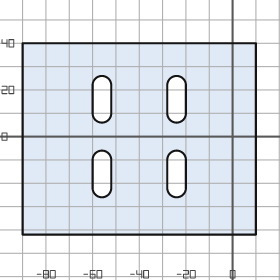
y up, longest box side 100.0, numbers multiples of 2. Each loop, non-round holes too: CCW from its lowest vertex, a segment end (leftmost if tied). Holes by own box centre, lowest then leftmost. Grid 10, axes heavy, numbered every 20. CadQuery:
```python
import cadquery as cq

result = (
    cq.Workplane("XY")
    .moveTo(-90.0, -42.0)
    .lineTo(10.0, -42.0)
    .lineTo(10.0, 40.0)
    .lineTo(-90.0, 40.0)
    .close()
    .moveTo(-60.0, -22.0)
    .threePointArc((-56.0, -26.0), (-52.0, -22.0))
    .lineTo(-52.0, -10.0)
    .threePointArc((-56.0, -6.0), (-60.0, -10.0))
    .close()
    .moveTo(-28.0, -22.0)
    .threePointArc((-24.0, -26.0), (-20.0, -22.0))
    .lineTo(-20.0, -10.0)
    .threePointArc((-24.0, -6.0), (-28.0, -10.0))
    .close()
    .moveTo(-60.0, 10.0)
    .threePointArc((-56.0, 6.0), (-52.0, 10.0))
    .lineTo(-52.0, 22.0)
    .threePointArc((-56.0, 26.0), (-60.0, 22.0))
    .close()
    .moveTo(-28.0, 10.0)
    .threePointArc((-24.0, 6.0), (-20.0, 10.0))
    .lineTo(-20.0, 22.0)
    .threePointArc((-24.0, 26.0), (-28.0, 22.0))
    .close()
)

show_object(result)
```